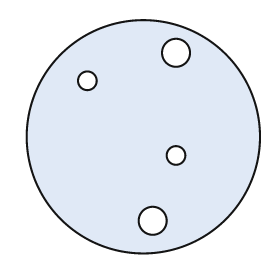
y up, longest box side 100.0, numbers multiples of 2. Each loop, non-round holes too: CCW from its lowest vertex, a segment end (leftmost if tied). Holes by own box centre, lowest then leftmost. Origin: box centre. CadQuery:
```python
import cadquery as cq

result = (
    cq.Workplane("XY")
    .moveTo(0.0, 0.0)
    .circle(50.0)
    .moveTo(4.0, -36.0)
    .circle(6.0)
    .moveTo(14.0, -8.0)
    .circle(4.0)
    .moveTo(-24.0, 24.0)
    .circle(4.0)
    .moveTo(14.0, 36.0)
    .circle(6.0)
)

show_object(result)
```